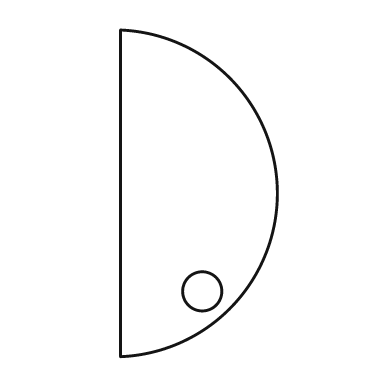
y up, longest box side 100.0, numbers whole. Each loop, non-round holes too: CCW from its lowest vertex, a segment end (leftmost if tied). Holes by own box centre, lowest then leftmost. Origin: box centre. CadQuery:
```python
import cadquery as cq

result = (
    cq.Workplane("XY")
    .moveTo(-24.0, -50.0)
    .threePointArc((24.0, 0.0), (-24.0, 50.0))
    .close()
    .moveTo(1.0, -30.0)
    .circle(6.0)
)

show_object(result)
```